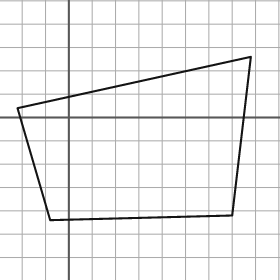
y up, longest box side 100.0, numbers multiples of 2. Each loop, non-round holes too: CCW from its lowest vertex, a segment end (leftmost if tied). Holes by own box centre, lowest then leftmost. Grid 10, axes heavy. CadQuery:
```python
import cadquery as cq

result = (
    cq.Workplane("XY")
    .moveTo(-8.0, -44.0)
    .lineTo(70.0, -42.0)
    .lineTo(78.0, 26.0)
    .lineTo(-22.0, 4.0)
    .close()
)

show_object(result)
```